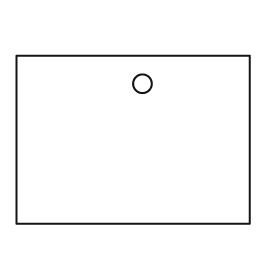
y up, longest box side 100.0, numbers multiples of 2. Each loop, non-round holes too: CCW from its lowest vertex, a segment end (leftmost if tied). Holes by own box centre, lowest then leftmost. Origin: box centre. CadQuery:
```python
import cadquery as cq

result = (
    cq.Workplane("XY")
    .moveTo(-50.0, -36.0)
    .lineTo(50.0, -36.0)
    .lineTo(50.0, 36.0)
    .lineTo(-50.0, 36.0)
    .close()
    .moveTo(4.0, 24.0)
    .circle(4.0)
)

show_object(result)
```